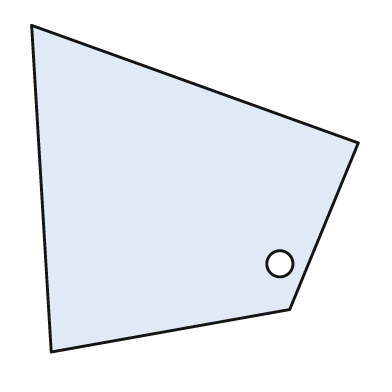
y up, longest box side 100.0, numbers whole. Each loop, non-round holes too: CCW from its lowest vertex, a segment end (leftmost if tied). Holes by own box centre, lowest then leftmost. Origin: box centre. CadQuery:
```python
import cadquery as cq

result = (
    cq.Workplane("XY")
    .moveTo(-44.0, -50.0)
    .lineTo(29.0, -37.0)
    .lineTo(50.0, 14.0)
    .lineTo(-50.0, 50.0)
    .close()
    .moveTo(26.0, -23.0)
    .circle(4.0)
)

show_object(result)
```